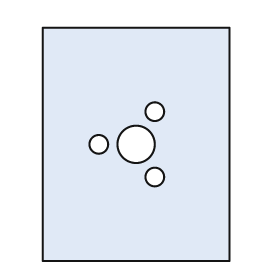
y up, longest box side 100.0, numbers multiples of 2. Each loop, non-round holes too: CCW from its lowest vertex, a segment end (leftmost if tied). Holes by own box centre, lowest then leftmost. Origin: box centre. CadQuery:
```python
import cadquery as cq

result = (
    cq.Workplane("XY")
    .moveTo(-40.0, -50.0)
    .lineTo(40.0, -50.0)
    .lineTo(40.0, 50.0)
    .lineTo(-40.0, 50.0)
    .close()
    .moveTo(8.0, -14.0)
    .circle(4.0)
    .moveTo(-16.0, 0.0)
    .circle(4.0)
    .moveTo(0.0, 0.0)
    .circle(8.0)
    .moveTo(8.0, 14.0)
    .circle(4.0)
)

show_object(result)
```